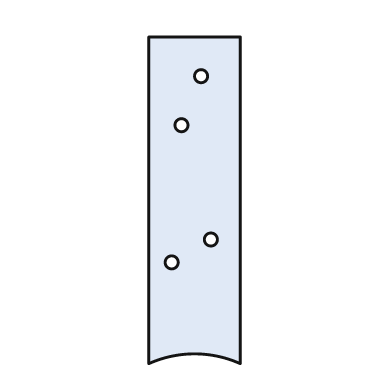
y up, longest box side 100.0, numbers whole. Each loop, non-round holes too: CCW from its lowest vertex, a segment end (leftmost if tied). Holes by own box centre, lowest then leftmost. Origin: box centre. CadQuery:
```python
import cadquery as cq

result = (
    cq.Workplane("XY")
    .moveTo(-14.0, -50.0)
    .threePointArc((0.0, -47.0), (14.0, -50.0))
    .lineTo(14.0, 50.0)
    .lineTo(-14.0, 50.0)
    .close()
    .moveTo(-7.0, -19.0)
    .circle(2.0)
    .moveTo(5.0, -12.0)
    .circle(2.0)
    .moveTo(-4.0, 23.0)
    .circle(2.0)
    .moveTo(2.0, 38.0)
    .circle(2.0)
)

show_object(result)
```